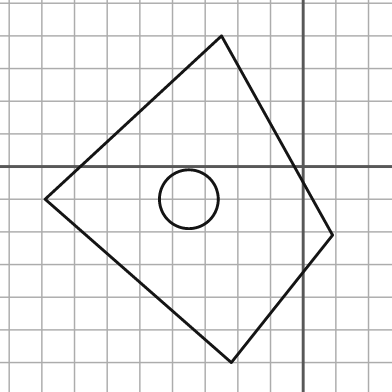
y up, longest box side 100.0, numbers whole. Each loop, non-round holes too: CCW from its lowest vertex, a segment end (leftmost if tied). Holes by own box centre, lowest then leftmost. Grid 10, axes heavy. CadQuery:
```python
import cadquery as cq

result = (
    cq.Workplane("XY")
    .moveTo(-22.0, -60.0)
    .lineTo(9.0, -21.0)
    .lineTo(-25.0, 40.0)
    .lineTo(-79.0, -10.0)
    .close()
    .moveTo(-35.0, -10.0)
    .circle(9.0)
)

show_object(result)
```